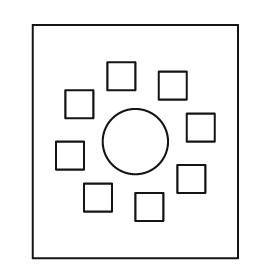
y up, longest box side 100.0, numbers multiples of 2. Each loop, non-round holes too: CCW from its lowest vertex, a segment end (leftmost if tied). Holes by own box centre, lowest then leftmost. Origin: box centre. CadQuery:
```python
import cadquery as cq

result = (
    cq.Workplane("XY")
    .moveTo(-44.0, -50.0)
    .lineTo(44.0, -50.0)
    .lineTo(44.0, 50.0)
    .lineTo(-44.0, 50.0)
    .close()
    .moveTo(0.0, -34.0)
    .lineTo(12.0, -34.0)
    .lineTo(12.0, -22.0)
    .lineTo(0.0, -22.0)
    .close()
    .moveTo(-22.0, -30.0)
    .lineTo(-10.0, -30.0)
    .lineTo(-10.0, -18.0)
    .lineTo(-22.0, -18.0)
    .close()
    .moveTo(18.0, -22.0)
    .lineTo(30.0, -22.0)
    .lineTo(30.0, -10.0)
    .lineTo(18.0, -10.0)
    .close()
    .moveTo(-34.0, -12.0)
    .lineTo(-22.0, -12.0)
    .lineTo(-22.0, 0.0)
    .lineTo(-34.0, 0.0)
    .close()
    .moveTo(0.0, 0.0)
    .circle(14.0)
    .moveTo(22.0, 0.0)
    .lineTo(34.0, 0.0)
    .lineTo(34.0, 12.0)
    .lineTo(22.0, 12.0)
    .close()
    .moveTo(-30.0, 10.0)
    .lineTo(-18.0, 10.0)
    .lineTo(-18.0, 22.0)
    .lineTo(-30.0, 22.0)
    .close()
    .moveTo(10.0, 18.0)
    .lineTo(22.0, 18.0)
    .lineTo(22.0, 30.0)
    .lineTo(10.0, 30.0)
    .close()
    .moveTo(-12.0, 22.0)
    .lineTo(0.0, 22.0)
    .lineTo(0.0, 34.0)
    .lineTo(-12.0, 34.0)
    .close()
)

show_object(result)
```